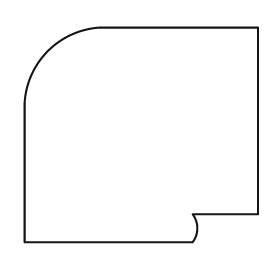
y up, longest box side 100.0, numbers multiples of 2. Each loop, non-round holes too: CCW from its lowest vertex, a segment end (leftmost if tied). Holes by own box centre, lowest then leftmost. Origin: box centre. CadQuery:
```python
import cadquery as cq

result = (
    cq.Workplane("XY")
    .moveTo(-50.0, -46.0)
    .lineTo(22.0, -46.0)
    .threePointArc((24.0, -40.0), (22.0, -34.0))
    .lineTo(50.0, -34.0)
    .lineTo(50.0, 46.0)
    .lineTo(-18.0, 46.0)
    .threePointArc((-40.0, 36.0), (-50.0, 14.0))
    .close()
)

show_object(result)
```